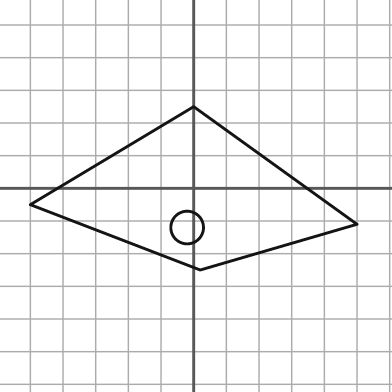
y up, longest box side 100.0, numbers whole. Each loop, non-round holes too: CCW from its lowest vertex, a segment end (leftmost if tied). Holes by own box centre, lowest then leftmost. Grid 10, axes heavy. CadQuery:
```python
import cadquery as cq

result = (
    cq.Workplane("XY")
    .moveTo(2.0, -25.0)
    .lineTo(50.0, -11.0)
    .lineTo(0.0, 25.0)
    .lineTo(-50.0, -5.0)
    .close()
    .moveTo(-2.0, -12.0)
    .circle(5.0)
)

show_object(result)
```